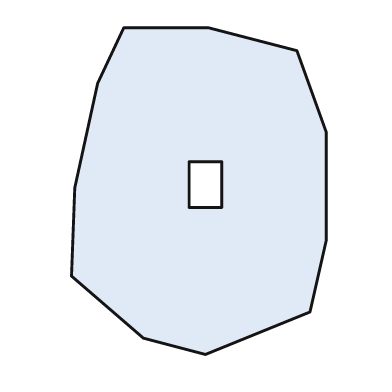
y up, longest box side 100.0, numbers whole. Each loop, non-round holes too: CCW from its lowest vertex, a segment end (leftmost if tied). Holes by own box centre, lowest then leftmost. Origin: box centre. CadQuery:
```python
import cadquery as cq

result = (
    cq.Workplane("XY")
    .moveTo(2.0, -50.0)
    .lineTo(34.0, -37.0)
    .lineTo(39.0, -15.0)
    .lineTo(39.0, 18.0)
    .lineTo(30.0, 43.0)
    .lineTo(3.0, 50.0)
    .lineTo(-23.0, 50.0)
    .lineTo(-31.0, 33.0)
    .lineTo(-38.0, 1.0)
    .lineTo(-39.0, -26.0)
    .lineTo(-17.0, -45.0)
    .close()
    .moveTo(-3.0, -5.0)
    .lineTo(7.0, -5.0)
    .lineTo(7.0, 9.0)
    .lineTo(-3.0, 9.0)
    .close()
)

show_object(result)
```